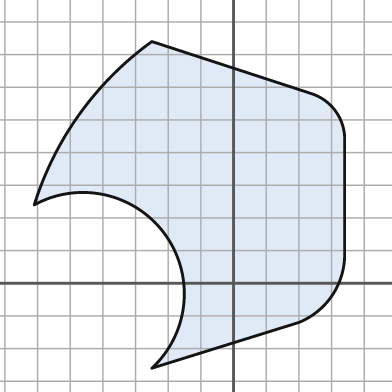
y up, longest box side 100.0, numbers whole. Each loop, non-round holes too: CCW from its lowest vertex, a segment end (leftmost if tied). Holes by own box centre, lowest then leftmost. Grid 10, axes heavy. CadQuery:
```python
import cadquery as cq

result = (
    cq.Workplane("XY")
    .moveTo(-25.0, -26.0)
    .lineTo(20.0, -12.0)
    .threePointArc((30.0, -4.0), (34.0, 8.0))
    .lineTo(34.0, 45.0)
    .threePointArc((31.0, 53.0), (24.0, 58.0))
    .lineTo(-25.0, 74.0)
    .threePointArc((-47.0, 52.0), (-61.0, 24.0))
    .threePointArc((-21.0, 15.0), (-25.0, -26.0))
    .close()
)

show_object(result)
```